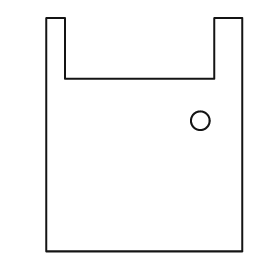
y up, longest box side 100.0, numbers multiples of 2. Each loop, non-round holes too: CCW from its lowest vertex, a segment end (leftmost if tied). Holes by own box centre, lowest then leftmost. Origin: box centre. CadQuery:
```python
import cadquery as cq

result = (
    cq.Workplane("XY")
    .moveTo(-42.0, -50.0)
    .lineTo(42.0, -50.0)
    .lineTo(42.0, 50.0)
    .lineTo(30.0, 50.0)
    .lineTo(30.0, 24.0)
    .lineTo(-34.0, 24.0)
    .lineTo(-34.0, 50.0)
    .lineTo(-42.0, 50.0)
    .close()
    .moveTo(24.0, 6.0)
    .circle(4.0)
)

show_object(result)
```